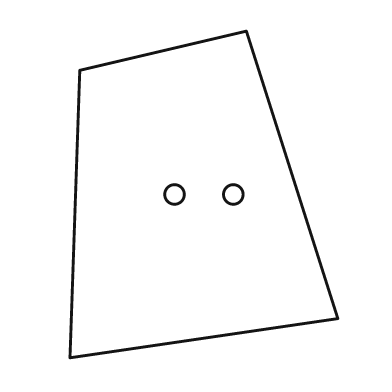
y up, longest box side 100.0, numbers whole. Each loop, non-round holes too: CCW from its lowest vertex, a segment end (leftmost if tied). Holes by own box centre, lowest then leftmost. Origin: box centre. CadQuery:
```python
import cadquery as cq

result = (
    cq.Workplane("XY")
    .moveTo(-41.0, -50.0)
    .lineTo(41.0, -38.0)
    .lineTo(13.0, 50.0)
    .lineTo(-38.0, 38.0)
    .close()
    .moveTo(-9.0, 0.0)
    .circle(3.0)
    .moveTo(9.0, 0.0)
    .circle(3.0)
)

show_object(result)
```